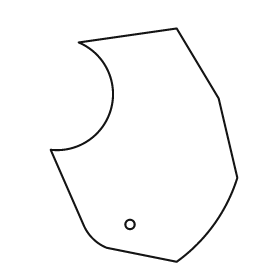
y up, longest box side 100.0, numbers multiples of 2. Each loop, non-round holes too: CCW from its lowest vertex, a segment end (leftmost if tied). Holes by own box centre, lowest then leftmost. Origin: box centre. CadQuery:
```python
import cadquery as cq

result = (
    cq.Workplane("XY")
    .moveTo(14.0, -50.0)
    .threePointArc((30.0, -34.0), (40.0, -14.0))
    .lineTo(32.0, 20.0)
    .lineTo(14.0, 50.0)
    .lineTo(-28.0, 44.0)
    .threePointArc((-14.0, 16.0), (-40.0, -2.0))
    .lineTo(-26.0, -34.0)
    .threePointArc((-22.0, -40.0), (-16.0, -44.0))
    .close()
    .moveTo(-6.0, -34.0)
    .circle(2.0)
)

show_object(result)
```